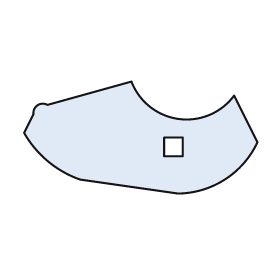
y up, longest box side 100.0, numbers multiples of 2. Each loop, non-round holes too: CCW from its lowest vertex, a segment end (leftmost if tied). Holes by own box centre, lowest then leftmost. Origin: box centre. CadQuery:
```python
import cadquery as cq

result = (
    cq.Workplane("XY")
    .moveTo(16.0, -24.0)
    .threePointArc((36.0, -18.0), (50.0, -2.0))
    .lineTo(40.0, 18.0)
    .threePointArc((16.0, 8.0), (-4.0, 24.0))
    .lineTo(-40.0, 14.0)
    .threePointArc((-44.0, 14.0), (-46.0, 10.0))
    .lineTo(-50.0, 2.0)
    .threePointArc((-40.0, -10.0), (-26.0, -18.0))
    .close()
    .moveTo(10.0, -8.0)
    .lineTo(18.0, -8.0)
    .lineTo(18.0, 0.0)
    .lineTo(10.0, 0.0)
    .close()
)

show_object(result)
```